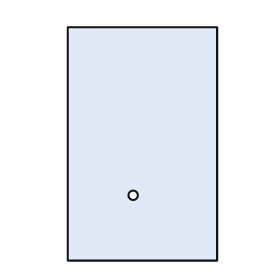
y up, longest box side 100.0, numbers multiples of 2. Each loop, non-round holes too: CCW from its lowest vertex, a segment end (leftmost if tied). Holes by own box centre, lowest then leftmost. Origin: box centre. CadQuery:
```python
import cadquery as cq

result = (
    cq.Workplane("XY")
    .moveTo(-32.0, -50.0)
    .lineTo(32.0, -50.0)
    .lineTo(32.0, 50.0)
    .lineTo(-32.0, 50.0)
    .close()
    .moveTo(-4.0, -22.0)
    .circle(2.0)
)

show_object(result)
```